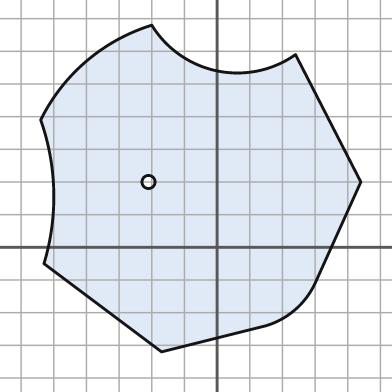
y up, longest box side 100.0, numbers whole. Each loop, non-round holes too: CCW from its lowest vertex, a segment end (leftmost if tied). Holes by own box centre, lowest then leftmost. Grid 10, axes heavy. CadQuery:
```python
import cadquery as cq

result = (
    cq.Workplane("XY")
    .moveTo(-17.0, -32.0)
    .lineTo(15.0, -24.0)
    .threePointArc((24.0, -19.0), (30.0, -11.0))
    .lineTo(44.0, 20.0)
    .lineTo(24.0, 59.0)
    .threePointArc((0.0, 54.0), (-20.0, 68.0))
    .threePointArc((-40.0, 57.0), (-54.0, 39.0))
    .threePointArc((-50.0, 17.0), (-53.0, -5.0))
    .close()
    .moveTo(-21.0, 20.0)
    .circle(2.0)
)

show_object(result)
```